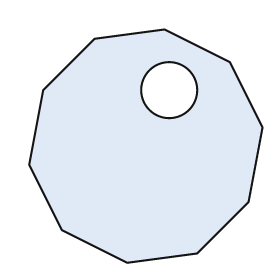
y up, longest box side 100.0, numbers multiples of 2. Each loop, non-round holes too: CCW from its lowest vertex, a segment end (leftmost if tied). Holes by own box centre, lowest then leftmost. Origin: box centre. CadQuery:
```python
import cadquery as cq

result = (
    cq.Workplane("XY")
    .moveTo(-8.0, -50.0)
    .lineTo(22.0, -46.0)
    .lineTo(44.0, -24.0)
    .lineTo(50.0, 8.0)
    .lineTo(36.0, 36.0)
    .lineTo(8.0, 50.0)
    .lineTo(-22.0, 46.0)
    .lineTo(-44.0, 24.0)
    .lineTo(-50.0, -8.0)
    .lineTo(-36.0, -36.0)
    .close()
    .moveTo(10.0, 24.0)
    .circle(12.0)
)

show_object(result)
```